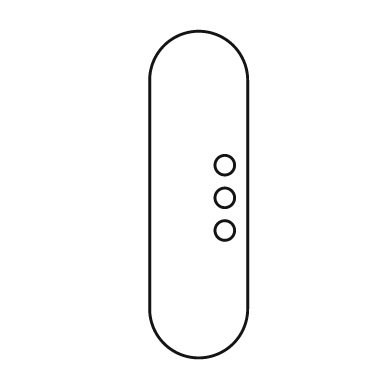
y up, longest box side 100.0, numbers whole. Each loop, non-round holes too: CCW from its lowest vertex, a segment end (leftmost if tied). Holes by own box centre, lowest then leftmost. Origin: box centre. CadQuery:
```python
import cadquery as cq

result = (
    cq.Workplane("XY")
    .moveTo(-15.0, -35.0)
    .threePointArc((0.0, -50.0), (15.0, -35.0))
    .lineTo(15.0, 35.0)
    .threePointArc((0.0, 50.0), (-15.0, 35.0))
    .close()
    .moveTo(8.0, -11.0)
    .circle(3.0)
    .moveTo(8.0, -1.0)
    .circle(3.0)
    .moveTo(8.0, 9.0)
    .circle(3.0)
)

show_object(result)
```